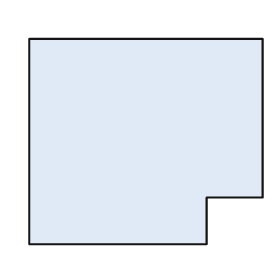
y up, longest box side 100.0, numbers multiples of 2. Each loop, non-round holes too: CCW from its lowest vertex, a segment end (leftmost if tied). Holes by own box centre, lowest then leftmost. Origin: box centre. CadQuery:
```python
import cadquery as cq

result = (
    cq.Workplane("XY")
    .moveTo(-50.0, -44.0)
    .lineTo(26.0, -44.0)
    .lineTo(26.0, -24.0)
    .lineTo(50.0, -24.0)
    .lineTo(50.0, 44.0)
    .lineTo(-50.0, 44.0)
    .close()
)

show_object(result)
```